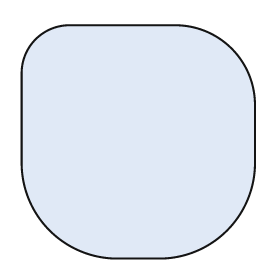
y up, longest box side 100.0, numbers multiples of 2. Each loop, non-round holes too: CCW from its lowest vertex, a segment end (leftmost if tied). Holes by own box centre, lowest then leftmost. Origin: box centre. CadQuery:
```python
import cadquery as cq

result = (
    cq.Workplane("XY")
    .moveTo(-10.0, -50.0)
    .lineTo(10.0, -50.0)
    .threePointArc((38.0, -38.0), (50.0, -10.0))
    .lineTo(50.0, 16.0)
    .threePointArc((40.0, 40.0), (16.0, 50.0))
    .lineTo(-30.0, 50.0)
    .threePointArc((-44.0, 44.0), (-50.0, 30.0))
    .lineTo(-50.0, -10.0)
    .threePointArc((-38.0, -38.0), (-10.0, -50.0))
    .close()
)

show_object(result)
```